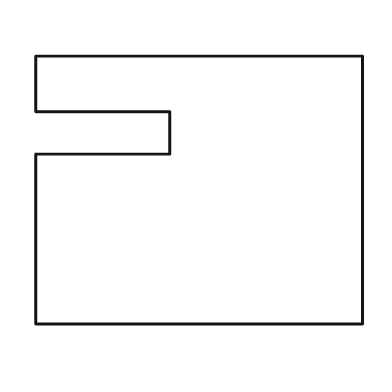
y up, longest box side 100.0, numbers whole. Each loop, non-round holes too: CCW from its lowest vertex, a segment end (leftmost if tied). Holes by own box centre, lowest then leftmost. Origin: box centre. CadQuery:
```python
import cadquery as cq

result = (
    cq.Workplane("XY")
    .moveTo(-50.0, -41.0)
    .lineTo(50.0, -41.0)
    .lineTo(50.0, 41.0)
    .lineTo(-50.0, 41.0)
    .lineTo(-50.0, 24.0)
    .lineTo(-9.0, 24.0)
    .lineTo(-9.0, 11.0)
    .lineTo(-50.0, 11.0)
    .close()
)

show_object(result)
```